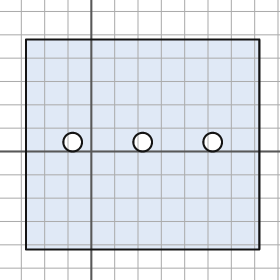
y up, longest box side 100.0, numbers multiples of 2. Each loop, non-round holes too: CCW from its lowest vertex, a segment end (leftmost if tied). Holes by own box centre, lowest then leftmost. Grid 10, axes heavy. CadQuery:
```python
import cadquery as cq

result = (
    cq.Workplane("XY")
    .moveTo(-28.0, -42.0)
    .lineTo(72.0, -42.0)
    .lineTo(72.0, 48.0)
    .lineTo(-28.0, 48.0)
    .close()
    .moveTo(-8.0, 4.0)
    .circle(4.0)
    .moveTo(22.0, 4.0)
    .circle(4.0)
    .moveTo(52.0, 4.0)
    .circle(4.0)
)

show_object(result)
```